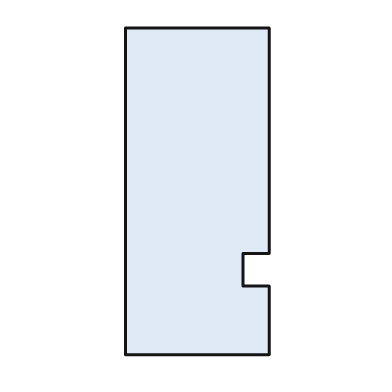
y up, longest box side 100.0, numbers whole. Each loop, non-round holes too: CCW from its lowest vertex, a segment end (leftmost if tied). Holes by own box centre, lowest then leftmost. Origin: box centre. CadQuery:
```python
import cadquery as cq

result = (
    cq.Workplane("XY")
    .moveTo(-22.0, -50.0)
    .lineTo(22.0, -50.0)
    .lineTo(22.0, -29.0)
    .lineTo(14.0, -29.0)
    .lineTo(14.0, -19.0)
    .lineTo(22.0, -19.0)
    .lineTo(22.0, 50.0)
    .lineTo(-22.0, 50.0)
    .close()
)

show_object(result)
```